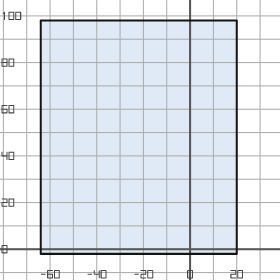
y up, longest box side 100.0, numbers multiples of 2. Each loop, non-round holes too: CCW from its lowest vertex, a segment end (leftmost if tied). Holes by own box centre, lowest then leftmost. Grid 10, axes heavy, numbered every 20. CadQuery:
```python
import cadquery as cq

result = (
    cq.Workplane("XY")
    .moveTo(-64.0, -2.0)
    .lineTo(20.0, -2.0)
    .lineTo(20.0, 98.0)
    .lineTo(-64.0, 98.0)
    .close()
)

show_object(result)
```